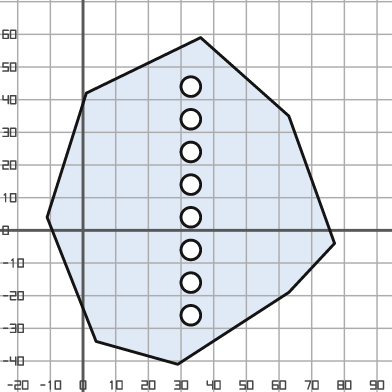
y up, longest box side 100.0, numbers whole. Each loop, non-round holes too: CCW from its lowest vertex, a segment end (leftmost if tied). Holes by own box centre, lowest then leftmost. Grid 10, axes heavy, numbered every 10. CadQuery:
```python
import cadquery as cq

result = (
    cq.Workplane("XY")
    .moveTo(29.0, -41.0)
    .lineTo(63.0, -19.0)
    .lineTo(77.0, -4.0)
    .lineTo(63.0, 35.0)
    .lineTo(36.0, 59.0)
    .lineTo(1.0, 42.0)
    .lineTo(-11.0, 4.0)
    .lineTo(4.0, -34.0)
    .close()
    .moveTo(33.0, -26.0)
    .circle(3.0)
    .moveTo(33.0, -16.0)
    .circle(3.0)
    .moveTo(33.0, -6.0)
    .circle(3.0)
    .moveTo(33.0, 4.0)
    .circle(3.0)
    .moveTo(33.0, 14.0)
    .circle(3.0)
    .moveTo(33.0, 24.0)
    .circle(3.0)
    .moveTo(33.0, 34.0)
    .circle(3.0)
    .moveTo(33.0, 44.0)
    .circle(3.0)
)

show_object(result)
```